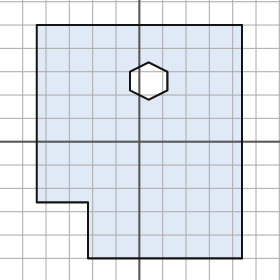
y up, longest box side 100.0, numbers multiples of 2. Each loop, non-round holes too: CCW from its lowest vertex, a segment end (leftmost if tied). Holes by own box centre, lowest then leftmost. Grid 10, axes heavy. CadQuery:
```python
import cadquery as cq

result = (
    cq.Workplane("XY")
    .moveTo(-22.0, -50.0)
    .lineTo(44.0, -50.0)
    .lineTo(44.0, 50.0)
    .lineTo(-44.0, 50.0)
    .lineTo(-44.0, -26.0)
    .lineTo(-22.0, -26.0)
    .close()
    .moveTo(4.0, 18.0)
    .lineTo(12.0, 22.0)
    .lineTo(12.0, 30.0)
    .lineTo(4.0, 34.0)
    .lineTo(-4.0, 30.0)
    .lineTo(-4.0, 22.0)
    .close()
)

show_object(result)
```